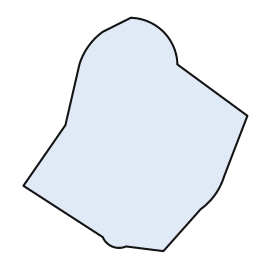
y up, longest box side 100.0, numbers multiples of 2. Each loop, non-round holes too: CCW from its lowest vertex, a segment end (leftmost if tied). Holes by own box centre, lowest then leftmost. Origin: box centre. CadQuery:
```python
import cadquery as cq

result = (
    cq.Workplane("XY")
    .moveTo(12.0, -50.0)
    .lineTo(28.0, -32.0)
    .threePointArc((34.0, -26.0), (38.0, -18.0))
    .lineTo(48.0, 8.0)
    .lineTo(18.0, 30.0)
    .threePointArc((12.0, 44.0), (-2.0, 50.0))
    .lineTo(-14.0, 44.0)
    .threePointArc((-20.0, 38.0), (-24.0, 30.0))
    .lineTo(-30.0, 4.0)
    .lineTo(-48.0, -22.0)
    .lineTo(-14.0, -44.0)
    .threePointArc((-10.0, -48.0), (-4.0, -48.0))
    .close()
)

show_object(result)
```